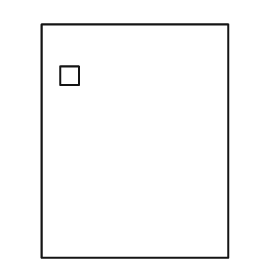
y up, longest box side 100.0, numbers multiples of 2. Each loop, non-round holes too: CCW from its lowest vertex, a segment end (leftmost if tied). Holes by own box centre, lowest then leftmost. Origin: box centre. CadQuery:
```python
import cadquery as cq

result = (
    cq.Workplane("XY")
    .moveTo(-40.0, -50.0)
    .lineTo(40.0, -50.0)
    .lineTo(40.0, 50.0)
    .lineTo(-40.0, 50.0)
    .close()
    .moveTo(-32.0, 24.0)
    .lineTo(-24.0, 24.0)
    .lineTo(-24.0, 32.0)
    .lineTo(-32.0, 32.0)
    .close()
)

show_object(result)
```